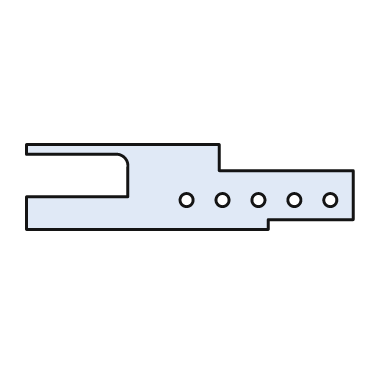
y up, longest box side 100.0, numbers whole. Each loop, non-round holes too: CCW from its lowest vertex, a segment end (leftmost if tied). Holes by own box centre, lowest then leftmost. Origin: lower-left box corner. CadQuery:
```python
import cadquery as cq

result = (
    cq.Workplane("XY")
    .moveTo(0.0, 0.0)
    .lineTo(74.0, 0.0)
    .lineTo(74.0, 3.0)
    .lineTo(100.0, 3.0)
    .lineTo(100.0, 18.0)
    .lineTo(59.0, 18.0)
    .lineTo(59.0, 26.0)
    .lineTo(0.0, 26.0)
    .lineTo(0.0, 23.0)
    .lineTo(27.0, 23.0)
    .threePointArc((30.0, 22.0), (31.0, 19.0))
    .lineTo(31.0, 10.0)
    .lineTo(0.0, 10.0)
    .close()
    .moveTo(49.0, 9.0)
    .circle(2.0)
    .moveTo(60.0, 9.0)
    .circle(2.0)
    .moveTo(71.0, 9.0)
    .circle(2.0)
    .moveTo(82.0, 9.0)
    .circle(2.0)
    .moveTo(93.0, 9.0)
    .circle(2.0)
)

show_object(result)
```